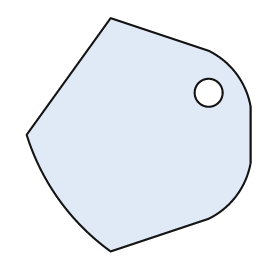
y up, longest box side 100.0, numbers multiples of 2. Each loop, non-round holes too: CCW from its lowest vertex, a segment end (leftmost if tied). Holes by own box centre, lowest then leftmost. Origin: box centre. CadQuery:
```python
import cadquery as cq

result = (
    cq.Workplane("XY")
    .moveTo(-12.0, -50.0)
    .lineTo(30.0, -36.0)
    .threePointArc((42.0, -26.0), (48.0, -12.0))
    .lineTo(48.0, 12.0)
    .threePointArc((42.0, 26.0), (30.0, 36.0))
    .lineTo(-12.0, 50.0)
    .lineTo(-48.0, 0.0)
    .threePointArc((-34.0, -28.0), (-12.0, -50.0))
    .close()
    .moveTo(30.0, 18.0)
    .circle(6.0)
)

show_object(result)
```